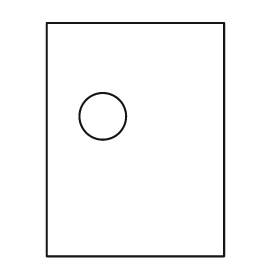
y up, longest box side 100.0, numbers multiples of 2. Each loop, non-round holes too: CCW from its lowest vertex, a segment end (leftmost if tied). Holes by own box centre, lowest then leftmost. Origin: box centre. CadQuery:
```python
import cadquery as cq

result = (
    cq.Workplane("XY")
    .moveTo(-38.0, -50.0)
    .lineTo(38.0, -50.0)
    .lineTo(38.0, 50.0)
    .lineTo(-38.0, 50.0)
    .close()
    .moveTo(-14.0, 10.0)
    .circle(10.0)
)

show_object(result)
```